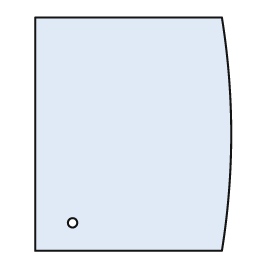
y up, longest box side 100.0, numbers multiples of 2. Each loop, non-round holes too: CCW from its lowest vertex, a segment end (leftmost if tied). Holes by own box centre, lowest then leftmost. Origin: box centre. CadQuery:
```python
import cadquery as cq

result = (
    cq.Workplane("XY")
    .moveTo(-42.0, -50.0)
    .lineTo(38.0, -50.0)
    .threePointArc((42.0, 0.0), (38.0, 50.0))
    .lineTo(-42.0, 50.0)
    .close()
    .moveTo(-26.0, -38.0)
    .circle(2.0)
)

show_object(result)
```